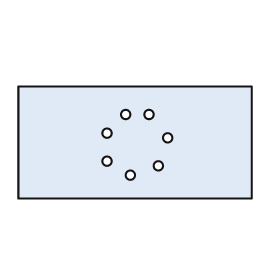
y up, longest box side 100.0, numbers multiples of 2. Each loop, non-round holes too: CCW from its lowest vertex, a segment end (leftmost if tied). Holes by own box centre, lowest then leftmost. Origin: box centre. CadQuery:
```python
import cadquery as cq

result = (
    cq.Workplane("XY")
    .moveTo(-50.0, -24.0)
    .lineTo(50.0, -24.0)
    .lineTo(50.0, 24.0)
    .lineTo(-50.0, 24.0)
    .close()
    .moveTo(-2.0, -14.0)
    .circle(2.0)
    .moveTo(10.0, -10.0)
    .circle(2.0)
    .moveTo(-12.0, -8.0)
    .circle(2.0)
    .moveTo(14.0, 2.0)
    .circle(2.0)
    .moveTo(-12.0, 4.0)
    .circle(2.0)
    .moveTo(-4.0, 12.0)
    .circle(2.0)
    .moveTo(6.0, 12.0)
    .circle(2.0)
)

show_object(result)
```